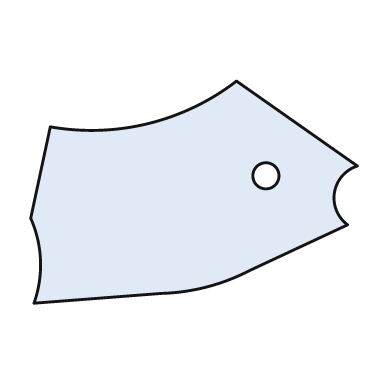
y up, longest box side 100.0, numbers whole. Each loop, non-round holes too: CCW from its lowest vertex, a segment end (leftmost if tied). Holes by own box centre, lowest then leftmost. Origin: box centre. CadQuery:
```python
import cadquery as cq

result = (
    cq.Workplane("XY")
    .moveTo(-49.0, -34.0)
    .lineTo(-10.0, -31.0)
    .threePointArc((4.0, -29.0), (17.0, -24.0))
    .lineTo(47.0, -10.0)
    .threePointArc((43.0, 0.0), (50.0, 8.0))
    .lineTo(13.0, 34.0)
    .threePointArc((-14.0, 21.0), (-44.0, 20.0))
    .lineTo(-50.0, -8.0)
    .threePointArc((-47.0, -21.0), (-49.0, -34.0))
    .close()
    .moveTo(22.0, 5.0)
    .circle(4.0)
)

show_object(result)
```